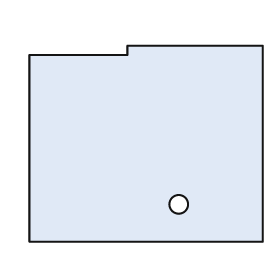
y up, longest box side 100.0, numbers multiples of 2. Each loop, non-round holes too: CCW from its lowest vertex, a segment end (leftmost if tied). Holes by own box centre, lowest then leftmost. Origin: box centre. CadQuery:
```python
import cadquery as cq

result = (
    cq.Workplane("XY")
    .moveTo(-50.0, -42.0)
    .lineTo(50.0, -42.0)
    .lineTo(50.0, 42.0)
    .lineTo(-8.0, 42.0)
    .lineTo(-8.0, 38.0)
    .lineTo(-50.0, 38.0)
    .close()
    .moveTo(14.0, -26.0)
    .circle(4.0)
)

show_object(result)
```